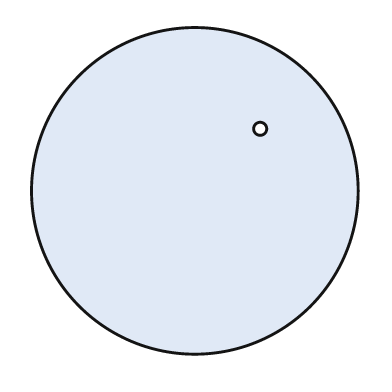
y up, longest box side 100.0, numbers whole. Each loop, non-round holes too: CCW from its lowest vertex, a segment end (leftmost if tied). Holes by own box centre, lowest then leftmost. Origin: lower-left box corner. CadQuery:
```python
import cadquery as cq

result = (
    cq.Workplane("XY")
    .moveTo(50.0, 50.0)
    .circle(50.0)
    .moveTo(70.0, 69.0)
    .circle(2.0)
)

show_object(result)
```